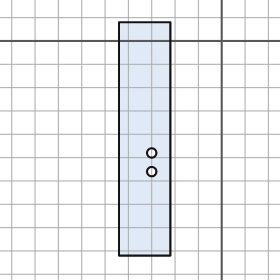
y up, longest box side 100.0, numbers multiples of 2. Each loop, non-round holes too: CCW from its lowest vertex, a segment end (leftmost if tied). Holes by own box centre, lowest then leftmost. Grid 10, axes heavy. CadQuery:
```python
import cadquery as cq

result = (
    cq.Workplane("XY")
    .moveTo(-44.0, -92.0)
    .lineTo(-22.0, -92.0)
    .lineTo(-22.0, 8.0)
    .lineTo(-44.0, 8.0)
    .close()
    .moveTo(-30.0, -56.0)
    .circle(2.0)
    .moveTo(-30.0, -48.0)
    .circle(2.0)
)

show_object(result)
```